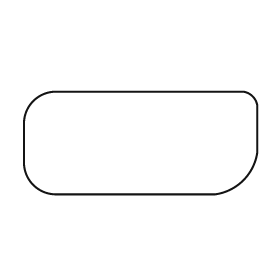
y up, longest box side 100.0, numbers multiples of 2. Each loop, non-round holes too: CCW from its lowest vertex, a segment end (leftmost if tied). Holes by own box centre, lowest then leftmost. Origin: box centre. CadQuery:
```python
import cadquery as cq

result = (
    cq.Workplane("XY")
    .moveTo(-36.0, -22.0)
    .lineTo(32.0, -22.0)
    .threePointArc((44.0, -16.0), (50.0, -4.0))
    .lineTo(50.0, 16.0)
    .threePointArc((48.0, 20.0), (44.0, 22.0))
    .lineTo(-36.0, 22.0)
    .threePointArc((-46.0, 18.0), (-50.0, 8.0))
    .lineTo(-50.0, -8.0)
    .threePointArc((-46.0, -18.0), (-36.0, -22.0))
    .close()
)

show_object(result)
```